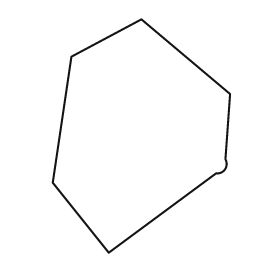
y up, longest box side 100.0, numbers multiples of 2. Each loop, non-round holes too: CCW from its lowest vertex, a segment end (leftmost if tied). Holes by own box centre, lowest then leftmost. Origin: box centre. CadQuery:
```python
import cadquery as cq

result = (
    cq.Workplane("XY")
    .moveTo(-14.0, -50.0)
    .lineTo(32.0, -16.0)
    .threePointArc((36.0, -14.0), (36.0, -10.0))
    .lineTo(38.0, 18.0)
    .lineTo(0.0, 50.0)
    .lineTo(-30.0, 34.0)
    .lineTo(-38.0, -20.0)
    .close()
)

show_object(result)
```